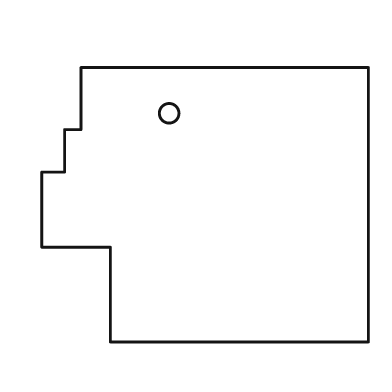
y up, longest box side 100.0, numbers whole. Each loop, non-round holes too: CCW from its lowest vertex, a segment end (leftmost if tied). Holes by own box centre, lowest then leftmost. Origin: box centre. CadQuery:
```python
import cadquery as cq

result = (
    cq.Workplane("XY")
    .moveTo(-29.0, -42.0)
    .lineTo(50.0, -42.0)
    .lineTo(50.0, 42.0)
    .lineTo(-38.0, 42.0)
    .lineTo(-38.0, 23.0)
    .lineTo(-43.0, 23.0)
    .lineTo(-43.0, 10.0)
    .lineTo(-50.0, 10.0)
    .lineTo(-50.0, -13.0)
    .lineTo(-29.0, -13.0)
    .close()
    .moveTo(-11.0, 28.0)
    .circle(3.0)
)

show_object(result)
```